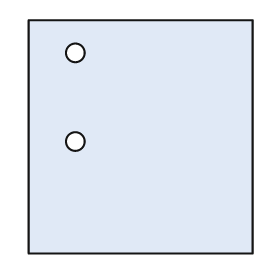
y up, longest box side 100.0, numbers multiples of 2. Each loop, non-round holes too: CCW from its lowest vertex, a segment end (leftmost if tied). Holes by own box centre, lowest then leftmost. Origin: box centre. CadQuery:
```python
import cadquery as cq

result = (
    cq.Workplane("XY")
    .moveTo(-48.0, -50.0)
    .lineTo(48.0, -50.0)
    .lineTo(48.0, 50.0)
    .lineTo(-48.0, 50.0)
    .close()
    .moveTo(-28.0, -2.0)
    .circle(4.0)
    .moveTo(-28.0, 36.0)
    .circle(4.0)
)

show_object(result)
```